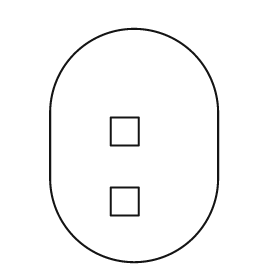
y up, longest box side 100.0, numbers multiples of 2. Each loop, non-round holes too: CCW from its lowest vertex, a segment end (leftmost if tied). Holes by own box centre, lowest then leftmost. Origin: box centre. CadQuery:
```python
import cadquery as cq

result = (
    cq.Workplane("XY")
    .moveTo(-36.0, -14.0)
    .threePointArc((0.0, -50.0), (36.0, -14.0))
    .lineTo(36.0, 14.0)
    .threePointArc((0.0, 50.0), (-36.0, 14.0))
    .close()
    .moveTo(-10.0, -30.0)
    .lineTo(2.0, -30.0)
    .lineTo(2.0, -18.0)
    .lineTo(-10.0, -18.0)
    .close()
    .moveTo(-10.0, 0.0)
    .lineTo(2.0, 0.0)
    .lineTo(2.0, 12.0)
    .lineTo(-10.0, 12.0)
    .close()
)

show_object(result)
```